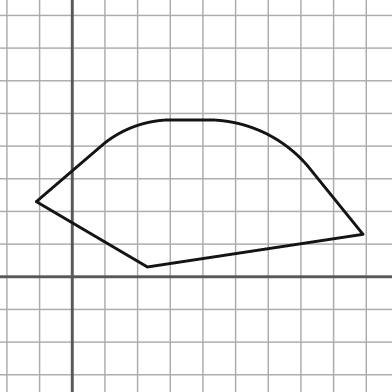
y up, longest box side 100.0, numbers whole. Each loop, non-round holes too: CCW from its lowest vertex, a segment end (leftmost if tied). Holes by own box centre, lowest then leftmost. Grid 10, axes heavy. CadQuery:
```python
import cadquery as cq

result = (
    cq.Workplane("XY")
    .moveTo(23.0, 3.0)
    .lineTo(89.0, 13.0)
    .lineTo(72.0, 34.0)
    .threePointArc((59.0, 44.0), (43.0, 48.0))
    .lineTo(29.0, 48.0)
    .threePointArc((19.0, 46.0), (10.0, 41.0))
    .lineTo(-11.0, 23.0)
    .close()
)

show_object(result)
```